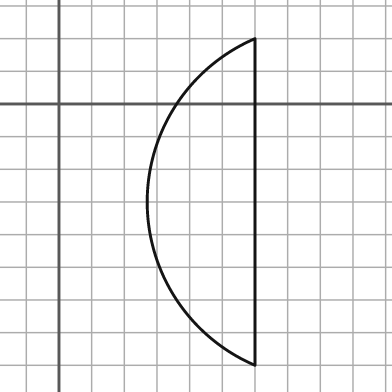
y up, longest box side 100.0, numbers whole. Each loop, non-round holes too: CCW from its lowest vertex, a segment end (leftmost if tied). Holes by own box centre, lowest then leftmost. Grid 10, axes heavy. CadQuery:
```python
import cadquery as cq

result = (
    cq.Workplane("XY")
    .moveTo(60.0, -80.0)
    .lineTo(60.0, 20.0)
    .threePointArc((27.0, -30.0), (60.0, -80.0))
    .close()
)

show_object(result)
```